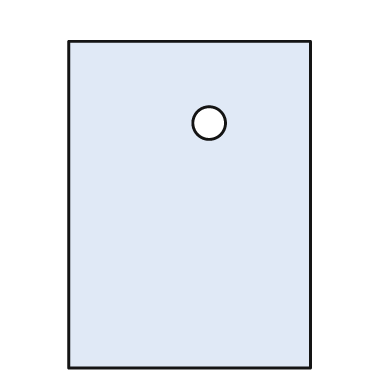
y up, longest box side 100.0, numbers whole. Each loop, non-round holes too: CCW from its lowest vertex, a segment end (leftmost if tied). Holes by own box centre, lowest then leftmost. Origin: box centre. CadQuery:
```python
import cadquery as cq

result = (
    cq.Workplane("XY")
    .moveTo(-37.0, -50.0)
    .lineTo(37.0, -50.0)
    .lineTo(37.0, 50.0)
    .lineTo(-37.0, 50.0)
    .close()
    .moveTo(6.0, 25.0)
    .circle(5.0)
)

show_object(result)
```